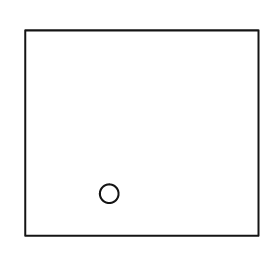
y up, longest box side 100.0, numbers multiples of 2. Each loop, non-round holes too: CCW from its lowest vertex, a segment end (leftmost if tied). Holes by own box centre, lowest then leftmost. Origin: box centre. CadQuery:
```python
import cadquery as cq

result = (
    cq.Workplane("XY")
    .moveTo(-50.0, -44.0)
    .lineTo(50.0, -44.0)
    .lineTo(50.0, 44.0)
    .lineTo(-50.0, 44.0)
    .close()
    .moveTo(-14.0, -26.0)
    .circle(4.0)
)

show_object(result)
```